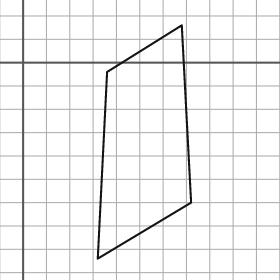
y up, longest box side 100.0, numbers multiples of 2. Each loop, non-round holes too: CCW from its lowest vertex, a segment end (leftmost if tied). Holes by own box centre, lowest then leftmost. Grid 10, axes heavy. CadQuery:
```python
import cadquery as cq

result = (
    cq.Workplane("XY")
    .moveTo(32.0, -84.0)
    .lineTo(72.0, -60.0)
    .lineTo(68.0, 16.0)
    .lineTo(36.0, -4.0)
    .close()
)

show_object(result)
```